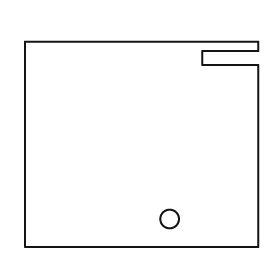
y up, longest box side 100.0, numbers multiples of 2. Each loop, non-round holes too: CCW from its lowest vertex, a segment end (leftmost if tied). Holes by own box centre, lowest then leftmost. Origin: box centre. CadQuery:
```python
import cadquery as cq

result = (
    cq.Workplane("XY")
    .moveTo(-50.0, -44.0)
    .lineTo(50.0, -44.0)
    .lineTo(50.0, 34.0)
    .lineTo(26.0, 34.0)
    .lineTo(26.0, 40.0)
    .lineTo(50.0, 40.0)
    .lineTo(50.0, 44.0)
    .lineTo(-50.0, 44.0)
    .close()
    .moveTo(12.0, -32.0)
    .circle(4.0)
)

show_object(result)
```